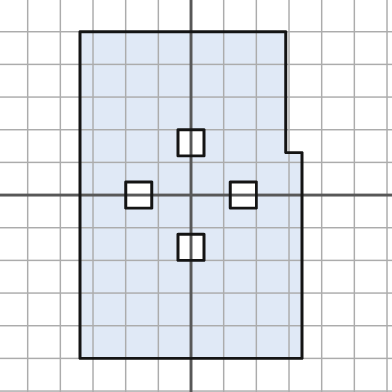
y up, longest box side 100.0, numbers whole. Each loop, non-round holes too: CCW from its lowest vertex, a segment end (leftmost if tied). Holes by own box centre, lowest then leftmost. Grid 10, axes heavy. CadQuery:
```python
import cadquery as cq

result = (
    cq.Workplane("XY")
    .moveTo(-34.0, -50.0)
    .lineTo(34.0, -50.0)
    .lineTo(34.0, 13.0)
    .lineTo(29.0, 13.0)
    .lineTo(29.0, 50.0)
    .lineTo(-34.0, 50.0)
    .close()
    .moveTo(-4.0, -20.0)
    .lineTo(4.0, -20.0)
    .lineTo(4.0, -12.0)
    .lineTo(-4.0, -12.0)
    .close()
    .moveTo(-20.0, -4.0)
    .lineTo(-12.0, -4.0)
    .lineTo(-12.0, 4.0)
    .lineTo(-20.0, 4.0)
    .close()
    .moveTo(12.0, -4.0)
    .lineTo(20.0, -4.0)
    .lineTo(20.0, 4.0)
    .lineTo(12.0, 4.0)
    .close()
    .moveTo(-4.0, 12.0)
    .lineTo(4.0, 12.0)
    .lineTo(4.0, 20.0)
    .lineTo(-4.0, 20.0)
    .close()
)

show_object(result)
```